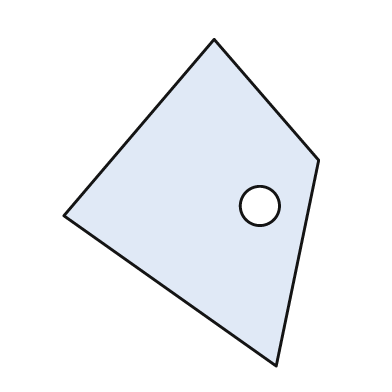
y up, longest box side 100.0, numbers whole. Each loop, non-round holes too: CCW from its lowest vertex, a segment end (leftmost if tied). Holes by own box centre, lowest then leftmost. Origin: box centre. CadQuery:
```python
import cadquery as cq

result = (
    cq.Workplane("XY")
    .moveTo(26.0, -50.0)
    .lineTo(39.0, 13.0)
    .lineTo(7.0, 50.0)
    .lineTo(-39.0, -4.0)
    .close()
    .moveTo(21.0, -1.0)
    .circle(6.0)
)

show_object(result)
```